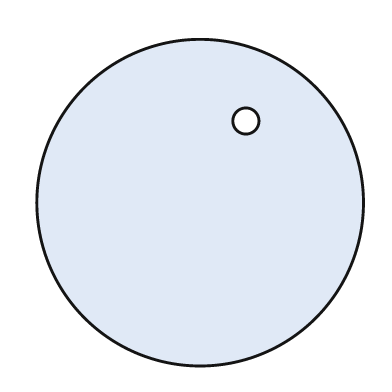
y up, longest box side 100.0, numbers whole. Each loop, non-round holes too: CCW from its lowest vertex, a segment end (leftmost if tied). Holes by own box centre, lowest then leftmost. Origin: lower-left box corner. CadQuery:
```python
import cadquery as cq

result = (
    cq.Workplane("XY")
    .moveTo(50.0, 50.0)
    .circle(50.0)
    .moveTo(64.0, 75.0)
    .circle(4.0)
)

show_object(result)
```